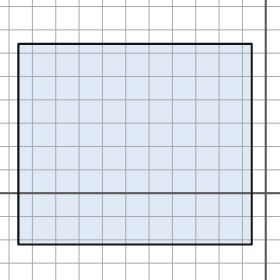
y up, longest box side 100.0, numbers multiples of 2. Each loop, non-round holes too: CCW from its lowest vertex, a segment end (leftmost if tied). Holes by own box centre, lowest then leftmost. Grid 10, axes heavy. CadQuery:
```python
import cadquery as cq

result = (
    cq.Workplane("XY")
    .moveTo(-106.0, -22.0)
    .lineTo(-6.0, -22.0)
    .lineTo(-6.0, 64.0)
    .lineTo(-106.0, 64.0)
    .close()
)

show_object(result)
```